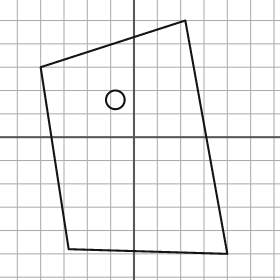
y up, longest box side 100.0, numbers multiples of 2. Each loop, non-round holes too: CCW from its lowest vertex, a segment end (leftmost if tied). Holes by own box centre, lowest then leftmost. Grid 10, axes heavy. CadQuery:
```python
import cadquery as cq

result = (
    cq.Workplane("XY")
    .moveTo(40.0, -50.0)
    .lineTo(22.0, 50.0)
    .lineTo(-40.0, 30.0)
    .lineTo(-28.0, -48.0)
    .close()
    .moveTo(-8.0, 16.0)
    .circle(4.0)
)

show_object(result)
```